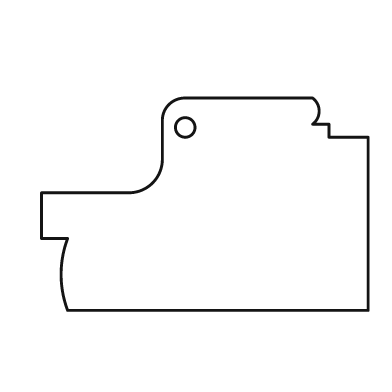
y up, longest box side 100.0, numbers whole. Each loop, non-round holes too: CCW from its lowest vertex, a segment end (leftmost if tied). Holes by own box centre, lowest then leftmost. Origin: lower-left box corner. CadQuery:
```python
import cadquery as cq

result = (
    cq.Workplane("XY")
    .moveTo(8.0, 0.0)
    .lineTo(100.0, 0.0)
    .lineTo(100.0, 53.0)
    .lineTo(88.0, 53.0)
    .lineTo(88.0, 57.0)
    .lineTo(83.0, 57.0)
    .threePointArc((85.0, 61.0), (83.0, 65.0))
    .lineTo(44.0, 65.0)
    .threePointArc((39.0, 63.0), (37.0, 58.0))
    .lineTo(37.0, 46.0)
    .threePointArc((34.0, 39.0), (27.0, 36.0))
    .lineTo(0.0, 36.0)
    .lineTo(0.0, 22.0)
    .lineTo(8.0, 22.0)
    .threePointArc((6.0, 11.0), (8.0, 0.0))
    .close()
    .moveTo(44.0, 56.0)
    .circle(3.0)
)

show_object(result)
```